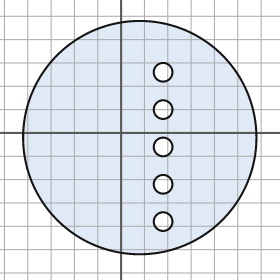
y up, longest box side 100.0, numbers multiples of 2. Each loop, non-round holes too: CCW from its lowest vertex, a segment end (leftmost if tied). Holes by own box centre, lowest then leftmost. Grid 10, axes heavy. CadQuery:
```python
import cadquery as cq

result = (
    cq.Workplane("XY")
    .moveTo(8.0, -2.0)
    .circle(50.0)
    .moveTo(18.0, -38.0)
    .circle(4.0)
    .moveTo(18.0, -22.0)
    .circle(4.0)
    .moveTo(18.0, -6.0)
    .circle(4.0)
    .moveTo(18.0, 10.0)
    .circle(4.0)
    .moveTo(18.0, 26.0)
    .circle(4.0)
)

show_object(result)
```